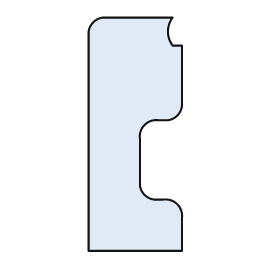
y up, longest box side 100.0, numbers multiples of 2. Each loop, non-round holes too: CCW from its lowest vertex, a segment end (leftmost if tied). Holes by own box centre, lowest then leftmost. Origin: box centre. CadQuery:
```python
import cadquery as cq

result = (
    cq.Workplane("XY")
    .moveTo(-20.0, -50.0)
    .lineTo(20.0, -50.0)
    .lineTo(20.0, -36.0)
    .threePointArc((18.0, -30.0), (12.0, -28.0))
    .lineTo(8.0, -28.0)
    .threePointArc((4.0, -26.0), (2.0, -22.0))
    .lineTo(2.0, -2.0)
    .threePointArc((4.0, 4.0), (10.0, 6.0))
    .lineTo(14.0, 6.0)
    .threePointArc((18.0, 8.0), (20.0, 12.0))
    .lineTo(20.0, 38.0)
    .lineTo(16.0, 38.0)
    .threePointArc((14.0, 44.0), (16.0, 50.0))
    .lineTo(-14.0, 50.0)
    .threePointArc((-18.0, 48.0), (-20.0, 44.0))
    .close()
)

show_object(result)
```